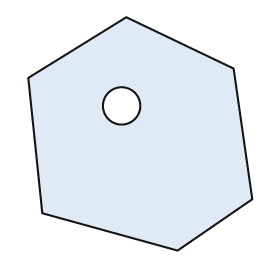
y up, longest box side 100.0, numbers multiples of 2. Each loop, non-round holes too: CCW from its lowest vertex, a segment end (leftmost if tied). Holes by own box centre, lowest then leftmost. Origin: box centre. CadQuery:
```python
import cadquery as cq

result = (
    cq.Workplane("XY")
    .moveTo(16.0, -50.0)
    .lineTo(48.0, -28.0)
    .lineTo(40.0, 28.0)
    .lineTo(-6.0, 50.0)
    .lineTo(-48.0, 24.0)
    .lineTo(-42.0, -34.0)
    .close()
    .moveTo(-8.0, 12.0)
    .circle(8.0)
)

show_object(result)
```